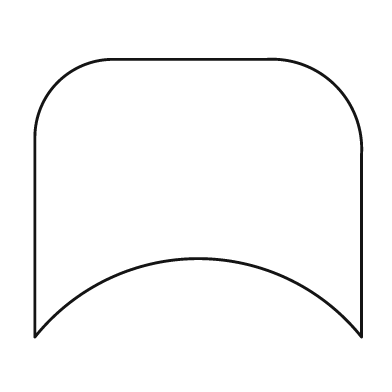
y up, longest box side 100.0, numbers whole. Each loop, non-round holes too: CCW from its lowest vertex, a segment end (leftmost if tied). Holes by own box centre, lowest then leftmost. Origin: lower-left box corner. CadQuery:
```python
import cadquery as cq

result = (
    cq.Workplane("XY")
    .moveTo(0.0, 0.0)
    .threePointArc((50.0, 24.0), (100.0, 0.0))
    .lineTo(100.0, 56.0)
    .threePointArc((92.0, 77.0), (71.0, 85.0))
    .lineTo(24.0, 85.0)
    .threePointArc((7.0, 78.0), (0.0, 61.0))
    .close()
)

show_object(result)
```